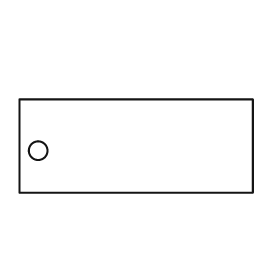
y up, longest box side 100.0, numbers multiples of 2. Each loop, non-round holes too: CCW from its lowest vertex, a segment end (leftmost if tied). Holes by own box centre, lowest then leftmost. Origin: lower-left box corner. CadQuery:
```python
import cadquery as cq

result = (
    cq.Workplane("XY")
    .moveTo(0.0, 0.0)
    .lineTo(100.0, 0.0)
    .lineTo(100.0, 40.0)
    .lineTo(0.0, 40.0)
    .close()
    .moveTo(8.0, 18.0)
    .circle(4.0)
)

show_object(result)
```